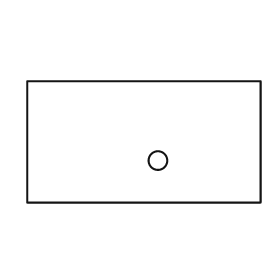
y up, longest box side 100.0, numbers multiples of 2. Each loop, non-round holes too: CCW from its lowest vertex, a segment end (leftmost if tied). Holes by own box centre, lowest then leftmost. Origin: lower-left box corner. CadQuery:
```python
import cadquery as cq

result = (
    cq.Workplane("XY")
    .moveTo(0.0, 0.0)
    .lineTo(100.0, 0.0)
    .lineTo(100.0, 52.0)
    .lineTo(0.0, 52.0)
    .close()
    .moveTo(56.0, 18.0)
    .circle(4.0)
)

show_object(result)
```